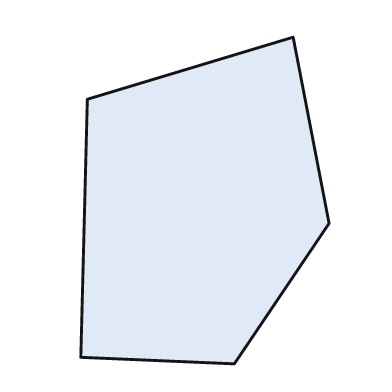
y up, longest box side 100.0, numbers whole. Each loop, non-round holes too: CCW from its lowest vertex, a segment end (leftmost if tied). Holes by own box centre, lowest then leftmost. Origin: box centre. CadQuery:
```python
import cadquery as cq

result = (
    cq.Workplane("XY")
    .moveTo(9.0, -50.0)
    .lineTo(38.0, -7.0)
    .lineTo(27.0, 50.0)
    .lineTo(-36.0, 31.0)
    .lineTo(-38.0, -48.0)
    .close()
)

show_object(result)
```